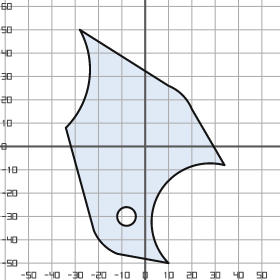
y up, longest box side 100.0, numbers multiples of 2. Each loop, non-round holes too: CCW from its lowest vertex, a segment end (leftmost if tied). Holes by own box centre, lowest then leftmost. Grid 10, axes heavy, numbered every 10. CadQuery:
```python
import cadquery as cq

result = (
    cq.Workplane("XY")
    .moveTo(10.0, -50.0)
    .threePointArc((6.0, -20.0), (34.0, -8.0))
    .lineTo(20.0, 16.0)
    .threePointArc((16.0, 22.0), (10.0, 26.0))
    .lineTo(-28.0, 50.0)
    .threePointArc((-24.0, 28.0), (-34.0, 8.0))
    .lineTo(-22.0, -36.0)
    .threePointArc((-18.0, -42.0), (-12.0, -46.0))
    .close()
    .moveTo(-8.0, -30.0)
    .circle(4.0)
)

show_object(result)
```